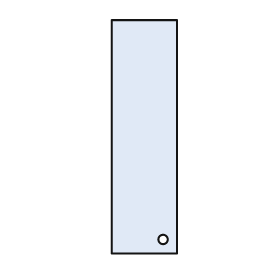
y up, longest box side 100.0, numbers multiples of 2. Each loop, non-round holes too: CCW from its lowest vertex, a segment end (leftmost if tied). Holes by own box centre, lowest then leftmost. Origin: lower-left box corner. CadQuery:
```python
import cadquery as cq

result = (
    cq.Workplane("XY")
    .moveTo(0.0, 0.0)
    .lineTo(28.0, 0.0)
    .lineTo(28.0, 100.0)
    .lineTo(0.0, 100.0)
    .close()
    .moveTo(22.0, 6.0)
    .circle(2.0)
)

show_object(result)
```